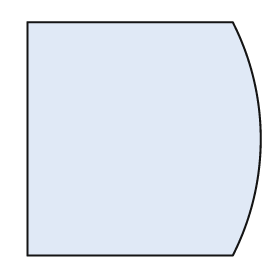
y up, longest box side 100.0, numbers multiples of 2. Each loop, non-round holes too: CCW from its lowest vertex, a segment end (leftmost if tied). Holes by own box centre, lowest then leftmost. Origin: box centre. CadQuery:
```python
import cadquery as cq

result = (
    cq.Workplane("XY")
    .moveTo(-50.0, -50.0)
    .lineTo(38.0, -50.0)
    .threePointArc((50.0, 0.0), (38.0, 50.0))
    .lineTo(-50.0, 50.0)
    .close()
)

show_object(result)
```